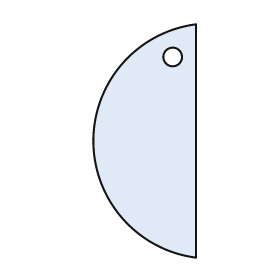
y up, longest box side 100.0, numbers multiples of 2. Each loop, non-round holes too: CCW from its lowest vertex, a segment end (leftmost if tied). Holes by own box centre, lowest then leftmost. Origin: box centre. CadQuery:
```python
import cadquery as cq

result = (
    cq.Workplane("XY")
    .moveTo(22.0, -50.0)
    .lineTo(22.0, 50.0)
    .threePointArc((-22.0, 0.0), (22.0, -50.0))
    .close()
    .moveTo(12.0, 36.0)
    .circle(4.0)
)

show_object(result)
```